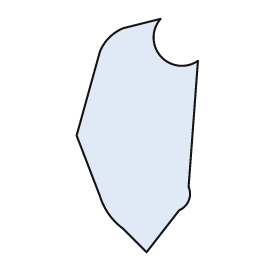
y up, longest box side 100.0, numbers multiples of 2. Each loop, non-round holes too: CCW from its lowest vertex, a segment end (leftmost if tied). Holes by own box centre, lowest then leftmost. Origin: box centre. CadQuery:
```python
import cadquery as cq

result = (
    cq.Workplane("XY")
    .moveTo(4.0, -50.0)
    .lineTo(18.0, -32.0)
    .threePointArc((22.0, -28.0), (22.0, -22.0))
    .lineTo(26.0, 32.0)
    .threePointArc((10.0, 34.0), (10.0, 50.0))
    .lineTo(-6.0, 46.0)
    .threePointArc((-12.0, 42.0), (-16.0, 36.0))
    .lineTo(-26.0, 0.0)
    .lineTo(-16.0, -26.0)
    .threePointArc((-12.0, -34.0), (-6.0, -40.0))
    .close()
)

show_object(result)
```